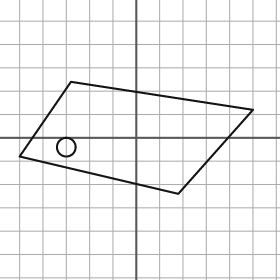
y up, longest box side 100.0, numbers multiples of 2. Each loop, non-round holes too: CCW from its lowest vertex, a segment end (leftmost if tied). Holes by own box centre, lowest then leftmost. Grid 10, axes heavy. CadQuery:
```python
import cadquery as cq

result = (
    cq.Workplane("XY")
    .moveTo(18.0, -24.0)
    .lineTo(50.0, 12.0)
    .lineTo(-28.0, 24.0)
    .lineTo(-50.0, -8.0)
    .close()
    .moveTo(-30.0, -4.0)
    .circle(4.0)
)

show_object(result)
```